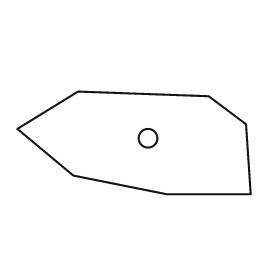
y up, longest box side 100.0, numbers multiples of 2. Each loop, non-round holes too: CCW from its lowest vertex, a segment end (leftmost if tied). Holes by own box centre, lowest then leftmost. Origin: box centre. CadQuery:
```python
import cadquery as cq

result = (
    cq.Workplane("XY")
    .moveTo(14.0, -22.0)
    .lineTo(50.0, -22.0)
    .lineTo(48.0, 8.0)
    .lineTo(32.0, 20.0)
    .lineTo(-24.0, 22.0)
    .lineTo(-50.0, 6.0)
    .lineTo(-26.0, -14.0)
    .close()
    .moveTo(6.0, 2.0)
    .circle(4.0)
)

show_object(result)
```